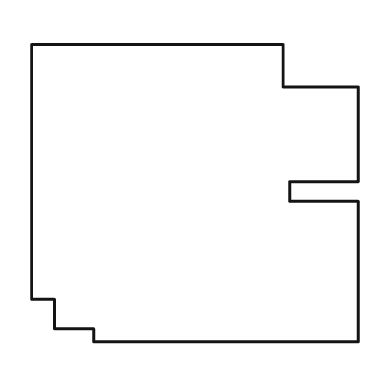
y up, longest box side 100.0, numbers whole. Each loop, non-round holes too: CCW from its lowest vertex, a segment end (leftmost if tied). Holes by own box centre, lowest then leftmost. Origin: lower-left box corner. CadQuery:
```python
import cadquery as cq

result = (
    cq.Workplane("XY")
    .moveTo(19.0, 0.0)
    .lineTo(100.0, 0.0)
    .lineTo(100.0, 43.0)
    .lineTo(79.0, 43.0)
    .lineTo(79.0, 49.0)
    .lineTo(100.0, 49.0)
    .lineTo(100.0, 78.0)
    .lineTo(77.0, 78.0)
    .lineTo(77.0, 91.0)
    .lineTo(0.0, 91.0)
    .lineTo(0.0, 13.0)
    .lineTo(7.0, 13.0)
    .lineTo(7.0, 4.0)
    .lineTo(19.0, 4.0)
    .close()
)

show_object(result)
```